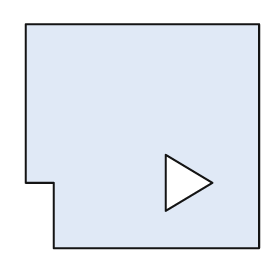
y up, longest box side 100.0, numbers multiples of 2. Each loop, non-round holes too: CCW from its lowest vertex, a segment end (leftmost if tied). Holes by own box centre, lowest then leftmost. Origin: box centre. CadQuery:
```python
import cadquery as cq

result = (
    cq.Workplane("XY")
    .moveTo(-38.0, -48.0)
    .lineTo(50.0, -48.0)
    .lineTo(50.0, 48.0)
    .lineTo(-50.0, 48.0)
    .lineTo(-50.0, -20.0)
    .lineTo(-38.0, -20.0)
    .close()
    .moveTo(10.0, -32.0)
    .lineTo(30.0, -20.0)
    .lineTo(10.0, -8.0)
    .close()
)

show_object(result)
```